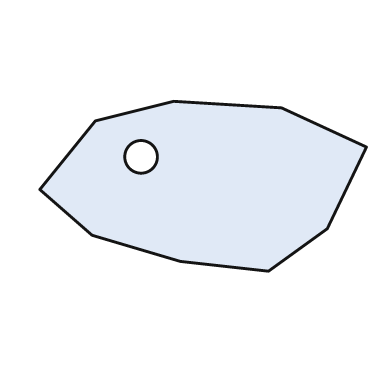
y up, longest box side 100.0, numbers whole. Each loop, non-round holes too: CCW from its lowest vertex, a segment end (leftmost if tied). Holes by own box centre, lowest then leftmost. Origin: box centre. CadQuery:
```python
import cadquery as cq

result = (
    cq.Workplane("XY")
    .moveTo(20.0, -26.0)
    .lineTo(38.0, -13.0)
    .lineTo(50.0, 12.0)
    .lineTo(24.0, 24.0)
    .lineTo(-9.0, 26.0)
    .lineTo(-33.0, 20.0)
    .lineTo(-50.0, -1.0)
    .lineTo(-34.0, -15.0)
    .lineTo(-7.0, -23.0)
    .close()
    .moveTo(-19.0, 9.0)
    .circle(5.0)
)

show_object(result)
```